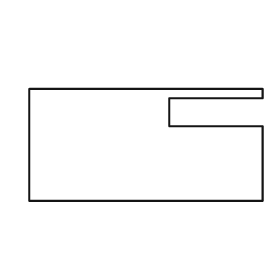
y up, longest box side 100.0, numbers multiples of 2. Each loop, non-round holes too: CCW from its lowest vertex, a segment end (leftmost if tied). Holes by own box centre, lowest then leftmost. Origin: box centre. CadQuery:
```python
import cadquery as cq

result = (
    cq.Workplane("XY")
    .moveTo(-50.0, -24.0)
    .lineTo(50.0, -24.0)
    .lineTo(50.0, 8.0)
    .lineTo(10.0, 8.0)
    .lineTo(10.0, 20.0)
    .lineTo(50.0, 20.0)
    .lineTo(50.0, 24.0)
    .lineTo(-50.0, 24.0)
    .close()
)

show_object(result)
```